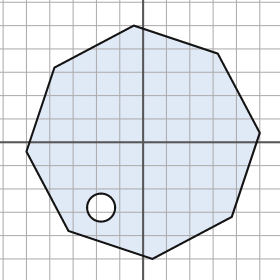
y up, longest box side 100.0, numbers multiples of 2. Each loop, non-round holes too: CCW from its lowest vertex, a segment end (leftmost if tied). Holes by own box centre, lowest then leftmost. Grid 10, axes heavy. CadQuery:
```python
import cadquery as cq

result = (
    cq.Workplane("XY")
    .moveTo(4.0, -50.0)
    .lineTo(38.0, -32.0)
    .lineTo(50.0, 4.0)
    .lineTo(32.0, 38.0)
    .lineTo(-4.0, 50.0)
    .lineTo(-38.0, 32.0)
    .lineTo(-50.0, -4.0)
    .lineTo(-32.0, -38.0)
    .close()
    .moveTo(-18.0, -28.0)
    .circle(6.0)
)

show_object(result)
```